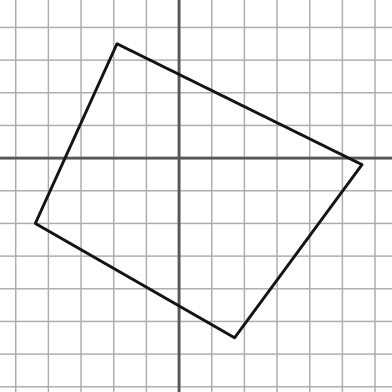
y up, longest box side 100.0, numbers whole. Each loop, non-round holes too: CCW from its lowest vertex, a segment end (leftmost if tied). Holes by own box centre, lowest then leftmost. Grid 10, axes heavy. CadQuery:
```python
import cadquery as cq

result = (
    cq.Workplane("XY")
    .moveTo(17.0, -55.0)
    .lineTo(56.0, -2.0)
    .lineTo(-19.0, 35.0)
    .lineTo(-44.0, -20.0)
    .close()
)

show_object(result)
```